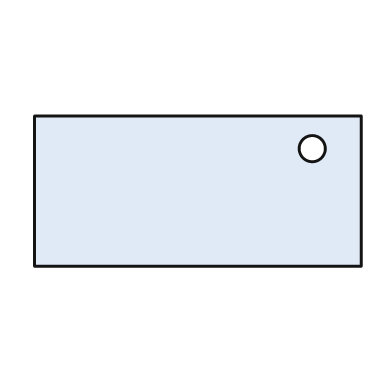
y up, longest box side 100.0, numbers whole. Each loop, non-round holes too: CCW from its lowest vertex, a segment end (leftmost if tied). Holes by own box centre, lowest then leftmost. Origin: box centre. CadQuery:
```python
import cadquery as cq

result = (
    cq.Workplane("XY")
    .moveTo(-50.0, -23.0)
    .lineTo(50.0, -23.0)
    .lineTo(50.0, 23.0)
    .lineTo(-50.0, 23.0)
    .close()
    .moveTo(35.0, 13.0)
    .circle(4.0)
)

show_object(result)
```